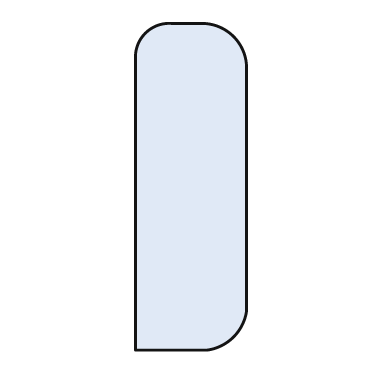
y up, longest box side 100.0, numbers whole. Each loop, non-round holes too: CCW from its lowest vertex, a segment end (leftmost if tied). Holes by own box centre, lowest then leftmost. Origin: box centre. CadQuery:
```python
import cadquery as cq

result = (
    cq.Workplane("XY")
    .moveTo(-17.0, -50.0)
    .lineTo(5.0, -50.0)
    .threePointArc((13.0, -46.0), (17.0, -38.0))
    .lineTo(17.0, 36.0)
    .threePointArc((13.0, 46.0), (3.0, 50.0))
    .lineTo(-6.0, 50.0)
    .threePointArc((-14.0, 47.0), (-17.0, 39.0))
    .close()
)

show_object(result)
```